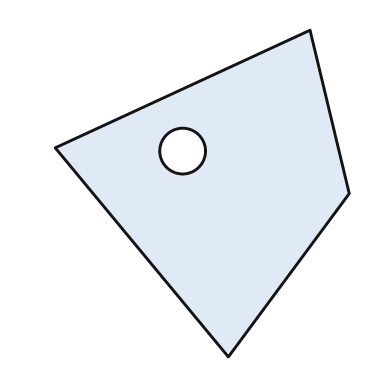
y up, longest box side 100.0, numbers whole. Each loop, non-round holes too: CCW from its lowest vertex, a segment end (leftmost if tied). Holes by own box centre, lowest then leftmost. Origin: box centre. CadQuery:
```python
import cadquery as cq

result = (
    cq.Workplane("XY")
    .moveTo(8.0, -50.0)
    .lineTo(45.0, 0.0)
    .lineTo(33.0, 50.0)
    .lineTo(-45.0, 14.0)
    .close()
    .moveTo(-6.0, 13.0)
    .circle(7.0)
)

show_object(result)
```